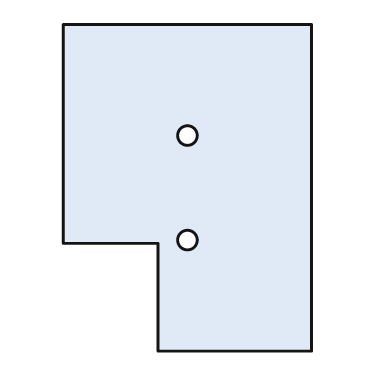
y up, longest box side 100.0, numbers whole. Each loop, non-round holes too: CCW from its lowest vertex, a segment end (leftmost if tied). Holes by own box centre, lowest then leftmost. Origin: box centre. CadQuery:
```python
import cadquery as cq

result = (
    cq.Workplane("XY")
    .moveTo(-9.0, -50.0)
    .lineTo(38.0, -50.0)
    .lineTo(38.0, 50.0)
    .lineTo(-38.0, 50.0)
    .lineTo(-38.0, -17.0)
    .lineTo(-9.0, -17.0)
    .close()
    .moveTo(0.0, -16.0)
    .circle(3.0)
    .moveTo(0.0, 16.0)
    .circle(3.0)
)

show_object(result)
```